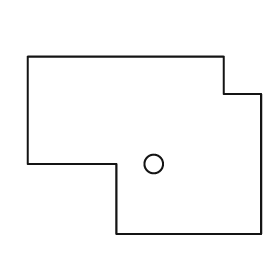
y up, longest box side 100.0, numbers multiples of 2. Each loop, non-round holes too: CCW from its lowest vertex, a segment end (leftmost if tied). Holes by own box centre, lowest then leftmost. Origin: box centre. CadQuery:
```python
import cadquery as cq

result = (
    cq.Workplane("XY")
    .moveTo(-12.0, -38.0)
    .lineTo(50.0, -38.0)
    .lineTo(50.0, 22.0)
    .lineTo(34.0, 22.0)
    .lineTo(34.0, 38.0)
    .lineTo(-50.0, 38.0)
    .lineTo(-50.0, -8.0)
    .lineTo(-12.0, -8.0)
    .close()
    .moveTo(4.0, -8.0)
    .circle(4.0)
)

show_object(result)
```